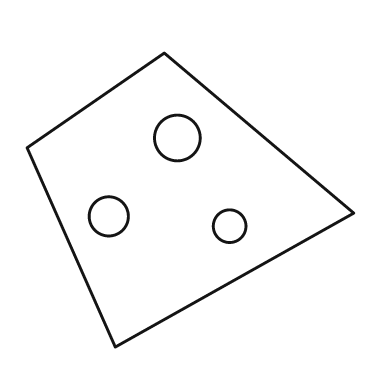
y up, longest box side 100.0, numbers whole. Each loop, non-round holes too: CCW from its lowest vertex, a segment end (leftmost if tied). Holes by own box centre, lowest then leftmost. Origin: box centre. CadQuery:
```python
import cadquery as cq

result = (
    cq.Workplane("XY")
    .moveTo(-23.0, -45.0)
    .lineTo(50.0, -4.0)
    .lineTo(-8.0, 45.0)
    .lineTo(-50.0, 16.0)
    .close()
    .moveTo(12.0, -8.0)
    .circle(5.0)
    .moveTo(-25.0, -5.0)
    .circle(6.0)
    .moveTo(-4.0, 19.0)
    .circle(7.0)
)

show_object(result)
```